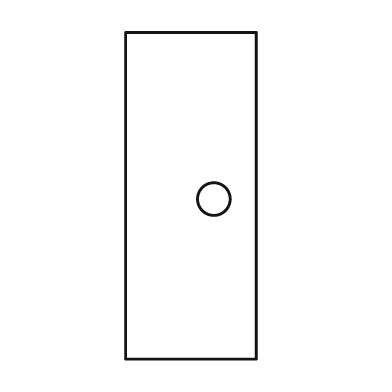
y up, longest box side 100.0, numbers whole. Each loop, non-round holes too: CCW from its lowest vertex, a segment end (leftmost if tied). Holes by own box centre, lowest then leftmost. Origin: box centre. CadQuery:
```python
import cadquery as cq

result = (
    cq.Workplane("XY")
    .moveTo(-20.0, -50.0)
    .lineTo(20.0, -50.0)
    .lineTo(20.0, 50.0)
    .lineTo(-20.0, 50.0)
    .close()
    .moveTo(7.0, -1.0)
    .circle(5.0)
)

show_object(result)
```